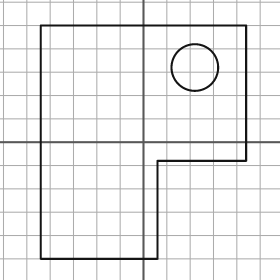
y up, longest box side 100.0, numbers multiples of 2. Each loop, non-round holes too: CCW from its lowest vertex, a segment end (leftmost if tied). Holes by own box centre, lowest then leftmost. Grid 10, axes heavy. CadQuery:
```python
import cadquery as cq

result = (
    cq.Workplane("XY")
    .moveTo(-44.0, -50.0)
    .lineTo(6.0, -50.0)
    .lineTo(6.0, -8.0)
    .lineTo(44.0, -8.0)
    .lineTo(44.0, 50.0)
    .lineTo(-44.0, 50.0)
    .close()
    .moveTo(22.0, 32.0)
    .circle(10.0)
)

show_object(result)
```